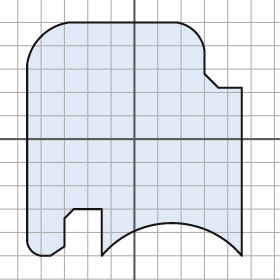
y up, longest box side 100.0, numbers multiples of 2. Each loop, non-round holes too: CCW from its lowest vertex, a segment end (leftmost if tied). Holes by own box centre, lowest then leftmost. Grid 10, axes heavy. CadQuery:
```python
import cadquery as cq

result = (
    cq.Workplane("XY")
    .moveTo(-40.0, -50.0)
    .lineTo(-36.0, -50.0)
    .lineTo(-30.0, -46.0)
    .lineTo(-30.0, -34.0)
    .lineTo(-26.0, -30.0)
    .lineTo(-14.0, -30.0)
    .lineTo(-14.0, -50.0)
    .threePointArc((16.0, -36.0), (46.0, -50.0))
    .lineTo(46.0, 22.0)
    .lineTo(36.0, 22.0)
    .lineTo(30.0, 28.0)
    .lineTo(30.0, 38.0)
    .threePointArc((26.0, 46.0), (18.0, 50.0))
    .lineTo(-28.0, 50.0)
    .threePointArc((-40.0, 44.0), (-46.0, 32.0))
    .lineTo(-46.0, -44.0)
    .threePointArc((-44.0, -48.0), (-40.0, -50.0))
    .close()
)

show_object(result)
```